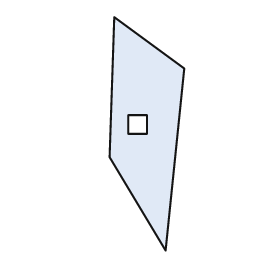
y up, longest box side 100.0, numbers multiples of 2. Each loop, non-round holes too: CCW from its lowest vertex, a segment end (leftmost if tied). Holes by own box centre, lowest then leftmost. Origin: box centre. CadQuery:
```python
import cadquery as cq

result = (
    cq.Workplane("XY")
    .moveTo(8.0, -50.0)
    .lineTo(16.0, 28.0)
    .lineTo(-14.0, 50.0)
    .lineTo(-16.0, -10.0)
    .close()
    .moveTo(-8.0, 0.0)
    .lineTo(0.0, 0.0)
    .lineTo(0.0, 8.0)
    .lineTo(-8.0, 8.0)
    .close()
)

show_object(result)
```